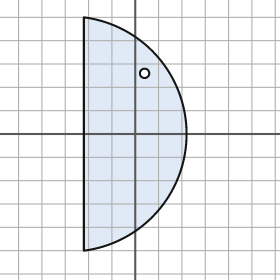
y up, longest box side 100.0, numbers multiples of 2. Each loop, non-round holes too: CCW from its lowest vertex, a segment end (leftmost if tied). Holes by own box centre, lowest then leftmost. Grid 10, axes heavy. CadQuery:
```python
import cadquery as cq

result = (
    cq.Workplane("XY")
    .moveTo(-22.0, -50.0)
    .threePointArc((22.0, 0.0), (-22.0, 50.0))
    .close()
    .moveTo(4.0, 26.0)
    .circle(2.0)
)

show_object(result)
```